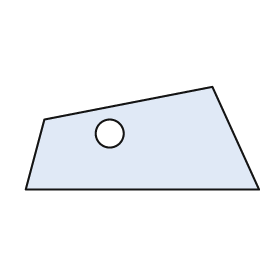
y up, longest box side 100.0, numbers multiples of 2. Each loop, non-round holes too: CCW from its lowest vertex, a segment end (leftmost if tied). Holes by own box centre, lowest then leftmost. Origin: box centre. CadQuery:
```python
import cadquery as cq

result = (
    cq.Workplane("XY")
    .moveTo(-50.0, -22.0)
    .lineTo(50.0, -22.0)
    .lineTo(30.0, 22.0)
    .lineTo(-42.0, 8.0)
    .close()
    .moveTo(-14.0, 2.0)
    .circle(6.0)
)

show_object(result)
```